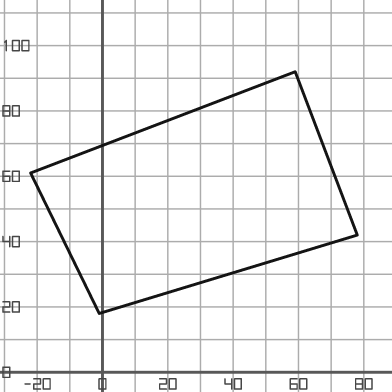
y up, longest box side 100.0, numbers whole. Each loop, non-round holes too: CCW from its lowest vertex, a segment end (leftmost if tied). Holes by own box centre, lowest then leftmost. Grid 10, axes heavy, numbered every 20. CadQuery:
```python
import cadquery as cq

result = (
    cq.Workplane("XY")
    .moveTo(-1.0, 18.0)
    .lineTo(78.0, 42.0)
    .lineTo(59.0, 92.0)
    .lineTo(-22.0, 61.0)
    .close()
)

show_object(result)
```